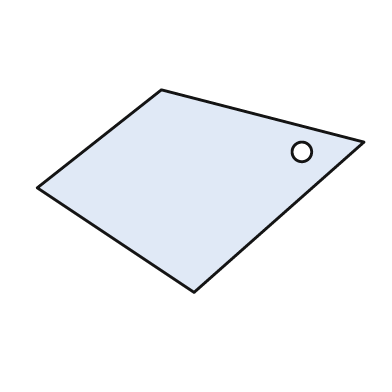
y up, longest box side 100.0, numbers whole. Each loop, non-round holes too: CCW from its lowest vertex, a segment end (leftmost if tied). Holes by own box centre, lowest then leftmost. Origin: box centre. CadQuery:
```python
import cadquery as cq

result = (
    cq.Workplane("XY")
    .moveTo(-2.0, -31.0)
    .lineTo(50.0, 15.0)
    .lineTo(-12.0, 31.0)
    .lineTo(-50.0, 1.0)
    .close()
    .moveTo(31.0, 12.0)
    .circle(3.0)
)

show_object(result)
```